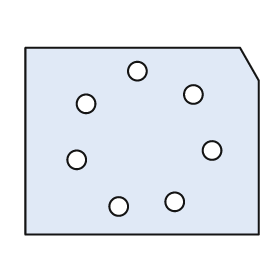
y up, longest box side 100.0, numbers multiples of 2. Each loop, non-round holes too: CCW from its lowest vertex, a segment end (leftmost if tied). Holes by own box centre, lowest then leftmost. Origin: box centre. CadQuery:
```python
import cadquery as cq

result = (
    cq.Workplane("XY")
    .moveTo(-50.0, -40.0)
    .lineTo(50.0, -40.0)
    .lineTo(50.0, 26.0)
    .lineTo(42.0, 40.0)
    .lineTo(-50.0, 40.0)
    .close()
    .moveTo(-10.0, -28.0)
    .circle(4.0)
    .moveTo(14.0, -26.0)
    .circle(4.0)
    .moveTo(-28.0, -8.0)
    .circle(4.0)
    .moveTo(30.0, -4.0)
    .circle(4.0)
    .moveTo(-24.0, 16.0)
    .circle(4.0)
    .moveTo(22.0, 20.0)
    .circle(4.0)
    .moveTo(-2.0, 30.0)
    .circle(4.0)
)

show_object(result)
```